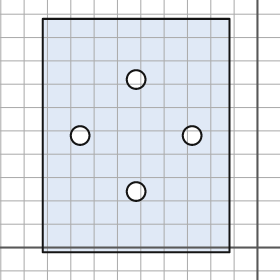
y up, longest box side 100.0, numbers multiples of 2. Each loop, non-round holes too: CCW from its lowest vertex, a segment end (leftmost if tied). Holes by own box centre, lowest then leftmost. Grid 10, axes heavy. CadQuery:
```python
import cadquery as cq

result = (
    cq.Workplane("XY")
    .moveTo(-92.0, -2.0)
    .lineTo(-12.0, -2.0)
    .lineTo(-12.0, 98.0)
    .lineTo(-92.0, 98.0)
    .close()
    .moveTo(-52.0, 24.0)
    .circle(4.0)
    .moveTo(-76.0, 48.0)
    .circle(4.0)
    .moveTo(-28.0, 48.0)
    .circle(4.0)
    .moveTo(-52.0, 72.0)
    .circle(4.0)
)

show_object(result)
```